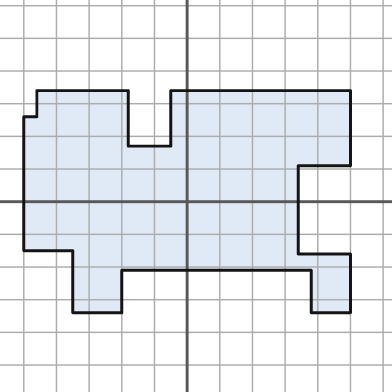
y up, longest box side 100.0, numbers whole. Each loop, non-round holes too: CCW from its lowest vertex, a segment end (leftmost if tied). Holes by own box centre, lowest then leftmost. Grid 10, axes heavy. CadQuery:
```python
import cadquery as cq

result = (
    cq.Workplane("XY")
    .moveTo(-35.0, -34.0)
    .lineTo(-20.0, -34.0)
    .lineTo(-20.0, -21.0)
    .lineTo(38.0, -21.0)
    .lineTo(38.0, -34.0)
    .lineTo(50.0, -34.0)
    .lineTo(50.0, -16.0)
    .lineTo(34.0, -16.0)
    .lineTo(34.0, 11.0)
    .lineTo(50.0, 11.0)
    .lineTo(50.0, 34.0)
    .lineTo(-5.0, 34.0)
    .lineTo(-5.0, 17.0)
    .lineTo(-18.0, 17.0)
    .lineTo(-18.0, 34.0)
    .lineTo(-46.0, 34.0)
    .lineTo(-46.0, 26.0)
    .lineTo(-50.0, 26.0)
    .lineTo(-50.0, -15.0)
    .lineTo(-35.0, -15.0)
    .close()
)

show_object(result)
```